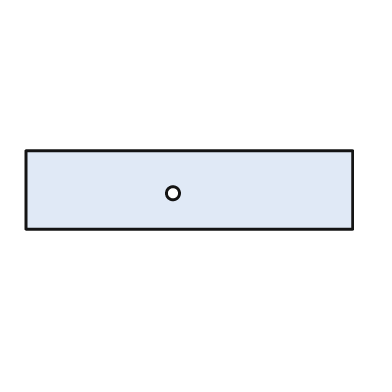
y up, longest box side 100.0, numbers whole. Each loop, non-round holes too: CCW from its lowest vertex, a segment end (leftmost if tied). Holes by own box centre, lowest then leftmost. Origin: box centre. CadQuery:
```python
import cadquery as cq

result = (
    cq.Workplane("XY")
    .moveTo(-50.0, -12.0)
    .lineTo(50.0, -12.0)
    .lineTo(50.0, 12.0)
    .lineTo(-50.0, 12.0)
    .close()
    .moveTo(-5.0, -1.0)
    .circle(2.0)
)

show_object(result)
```